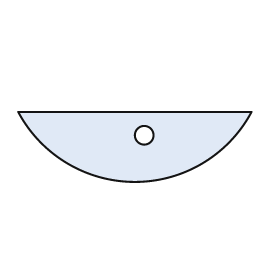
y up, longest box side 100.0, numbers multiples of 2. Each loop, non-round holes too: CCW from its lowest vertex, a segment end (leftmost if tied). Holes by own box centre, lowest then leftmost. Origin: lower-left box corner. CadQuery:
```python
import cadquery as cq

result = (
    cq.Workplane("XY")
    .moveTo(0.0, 30.0)
    .threePointArc((50.0, 0.0), (100.0, 30.0))
    .close()
    .moveTo(54.0, 20.0)
    .circle(4.0)
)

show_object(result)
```